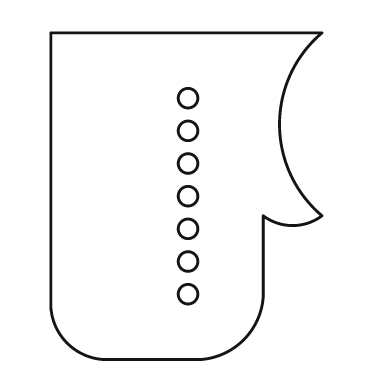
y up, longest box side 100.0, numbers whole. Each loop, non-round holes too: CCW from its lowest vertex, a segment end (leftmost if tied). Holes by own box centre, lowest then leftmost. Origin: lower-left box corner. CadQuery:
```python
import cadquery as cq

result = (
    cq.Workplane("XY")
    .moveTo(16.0, 0.0)
    .lineTo(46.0, 0.0)
    .threePointArc((59.0, 6.0), (65.0, 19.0))
    .lineTo(65.0, 44.0)
    .threePointArc((74.0, 41.0), (83.0, 44.0))
    .threePointArc((70.0, 72.0), (83.0, 100.0))
    .lineTo(0.0, 100.0)
    .lineTo(0.0, 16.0)
    .threePointArc((5.0, 5.0), (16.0, 0.0))
    .close()
    .moveTo(42.0, 20.0)
    .circle(3.0)
    .moveTo(42.0, 30.0)
    .circle(3.0)
    .moveTo(42.0, 40.0)
    .circle(3.0)
    .moveTo(42.0, 50.0)
    .circle(3.0)
    .moveTo(42.0, 60.0)
    .circle(3.0)
    .moveTo(42.0, 70.0)
    .circle(3.0)
    .moveTo(42.0, 80.0)
    .circle(3.0)
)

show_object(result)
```